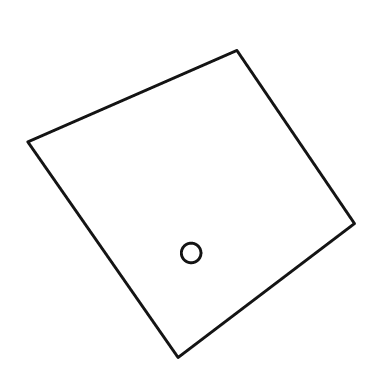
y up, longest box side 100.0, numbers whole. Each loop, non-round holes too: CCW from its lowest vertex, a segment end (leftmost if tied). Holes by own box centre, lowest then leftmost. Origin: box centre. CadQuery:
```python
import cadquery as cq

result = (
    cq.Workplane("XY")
    .moveTo(-4.0, -47.0)
    .lineTo(50.0, -6.0)
    .lineTo(14.0, 47.0)
    .lineTo(-50.0, 19.0)
    .close()
    .moveTo(0.0, -15.0)
    .circle(3.0)
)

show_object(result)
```